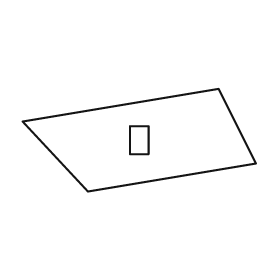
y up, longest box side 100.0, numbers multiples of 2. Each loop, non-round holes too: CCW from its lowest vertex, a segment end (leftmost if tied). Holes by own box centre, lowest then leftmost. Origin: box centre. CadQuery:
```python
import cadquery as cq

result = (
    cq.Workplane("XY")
    .moveTo(-22.0, -22.0)
    .lineTo(50.0, -10.0)
    .lineTo(34.0, 22.0)
    .lineTo(-50.0, 8.0)
    .close()
    .moveTo(-4.0, -6.0)
    .lineTo(4.0, -6.0)
    .lineTo(4.0, 6.0)
    .lineTo(-4.0, 6.0)
    .close()
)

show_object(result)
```